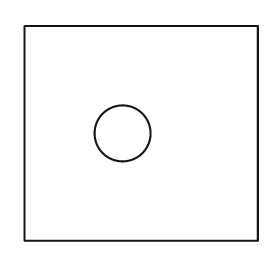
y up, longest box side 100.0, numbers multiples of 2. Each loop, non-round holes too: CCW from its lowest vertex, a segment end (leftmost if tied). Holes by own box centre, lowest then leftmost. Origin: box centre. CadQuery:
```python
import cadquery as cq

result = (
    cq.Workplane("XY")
    .moveTo(-50.0, -46.0)
    .lineTo(50.0, -46.0)
    .lineTo(50.0, 46.0)
    .lineTo(-50.0, 46.0)
    .close()
    .moveTo(-8.0, 0.0)
    .circle(12.0)
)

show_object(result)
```